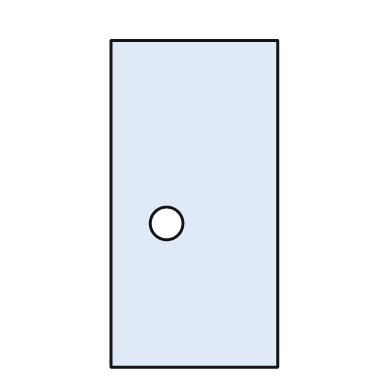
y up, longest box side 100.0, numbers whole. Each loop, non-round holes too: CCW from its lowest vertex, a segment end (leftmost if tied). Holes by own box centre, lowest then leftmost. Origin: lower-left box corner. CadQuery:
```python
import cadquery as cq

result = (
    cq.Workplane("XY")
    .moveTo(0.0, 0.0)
    .lineTo(51.0, 0.0)
    .lineTo(51.0, 100.0)
    .lineTo(0.0, 100.0)
    .close()
    .moveTo(17.0, 44.0)
    .circle(5.0)
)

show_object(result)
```